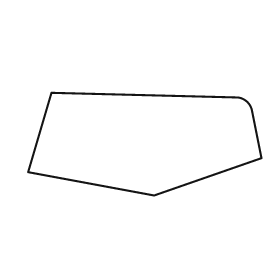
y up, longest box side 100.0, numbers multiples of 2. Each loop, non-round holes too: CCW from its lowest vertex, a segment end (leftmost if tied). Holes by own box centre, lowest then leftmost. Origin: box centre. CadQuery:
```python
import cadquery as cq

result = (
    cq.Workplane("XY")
    .moveTo(4.0, -22.0)
    .lineTo(50.0, -6.0)
    .lineTo(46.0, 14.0)
    .threePointArc((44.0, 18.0), (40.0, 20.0))
    .lineTo(-40.0, 22.0)
    .lineTo(-50.0, -12.0)
    .close()
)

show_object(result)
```